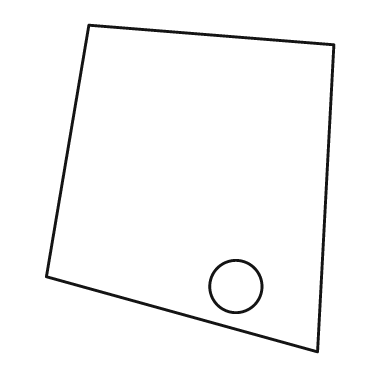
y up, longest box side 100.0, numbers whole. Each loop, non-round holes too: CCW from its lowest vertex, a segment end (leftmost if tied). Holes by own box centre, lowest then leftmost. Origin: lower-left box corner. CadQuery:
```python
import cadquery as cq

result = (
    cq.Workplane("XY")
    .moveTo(83.0, 0.0)
    .lineTo(88.0, 94.0)
    .lineTo(13.0, 100.0)
    .lineTo(0.0, 23.0)
    .close()
    .moveTo(58.0, 20.0)
    .circle(8.0)
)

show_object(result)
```